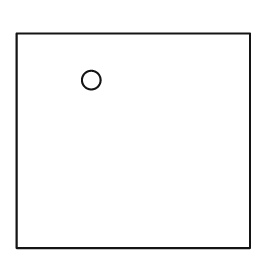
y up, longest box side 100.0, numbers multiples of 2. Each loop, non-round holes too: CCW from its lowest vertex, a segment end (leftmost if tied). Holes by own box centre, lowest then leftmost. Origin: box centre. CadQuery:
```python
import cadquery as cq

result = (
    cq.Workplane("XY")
    .moveTo(-50.0, -46.0)
    .lineTo(50.0, -46.0)
    .lineTo(50.0, 46.0)
    .lineTo(-50.0, 46.0)
    .close()
    .moveTo(-18.0, 26.0)
    .circle(4.0)
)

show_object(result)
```